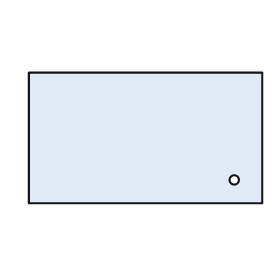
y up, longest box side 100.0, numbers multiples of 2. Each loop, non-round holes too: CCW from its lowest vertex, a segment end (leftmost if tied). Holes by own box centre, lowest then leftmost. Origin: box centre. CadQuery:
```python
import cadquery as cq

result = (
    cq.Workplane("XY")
    .moveTo(-50.0, -28.0)
    .lineTo(50.0, -28.0)
    .lineTo(50.0, 28.0)
    .lineTo(-50.0, 28.0)
    .close()
    .moveTo(38.0, -18.0)
    .circle(2.0)
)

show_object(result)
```